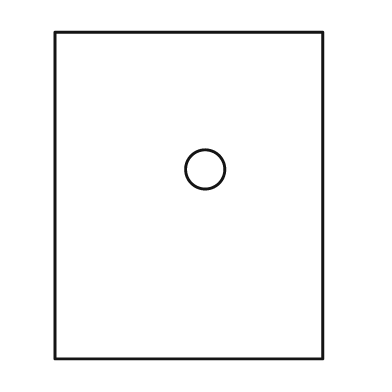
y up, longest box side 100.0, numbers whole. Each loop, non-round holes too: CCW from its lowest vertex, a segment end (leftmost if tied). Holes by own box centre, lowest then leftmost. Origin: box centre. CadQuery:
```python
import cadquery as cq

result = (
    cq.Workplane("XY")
    .moveTo(-41.0, -50.0)
    .lineTo(41.0, -50.0)
    .lineTo(41.0, 50.0)
    .lineTo(-41.0, 50.0)
    .close()
    .moveTo(5.0, 8.0)
    .circle(6.0)
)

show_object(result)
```